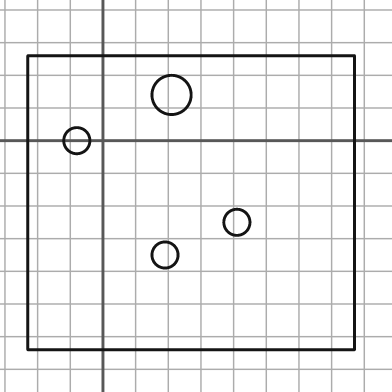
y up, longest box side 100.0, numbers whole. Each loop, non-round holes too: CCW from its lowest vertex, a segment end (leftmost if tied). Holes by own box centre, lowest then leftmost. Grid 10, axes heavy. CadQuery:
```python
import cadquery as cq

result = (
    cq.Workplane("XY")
    .moveTo(-23.0, -64.0)
    .lineTo(77.0, -64.0)
    .lineTo(77.0, 26.0)
    .lineTo(-23.0, 26.0)
    .close()
    .moveTo(19.0, -35.0)
    .circle(4.0)
    .moveTo(41.0, -25.0)
    .circle(4.0)
    .moveTo(-8.0, 0.0)
    .circle(4.0)
    .moveTo(21.0, 14.0)
    .circle(6.0)
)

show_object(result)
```